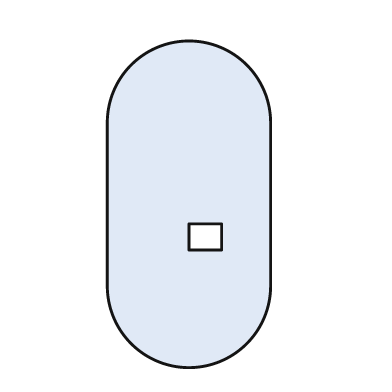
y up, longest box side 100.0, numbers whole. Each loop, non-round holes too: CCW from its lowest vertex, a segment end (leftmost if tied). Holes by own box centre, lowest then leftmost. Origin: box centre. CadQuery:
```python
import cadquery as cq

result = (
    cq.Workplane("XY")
    .moveTo(-25.0, -25.0)
    .threePointArc((0.0, -50.0), (25.0, -25.0))
    .lineTo(25.0, 25.0)
    .threePointArc((0.0, 50.0), (-25.0, 25.0))
    .close()
    .moveTo(0.0, -14.0)
    .lineTo(10.0, -14.0)
    .lineTo(10.0, -6.0)
    .lineTo(0.0, -6.0)
    .close()
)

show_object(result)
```